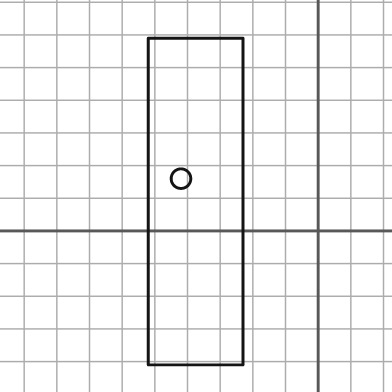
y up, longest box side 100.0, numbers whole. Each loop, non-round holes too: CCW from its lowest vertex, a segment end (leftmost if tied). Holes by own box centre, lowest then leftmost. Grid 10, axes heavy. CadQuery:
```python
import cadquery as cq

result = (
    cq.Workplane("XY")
    .moveTo(-52.0, -41.0)
    .lineTo(-23.0, -41.0)
    .lineTo(-23.0, 59.0)
    .lineTo(-52.0, 59.0)
    .close()
    .moveTo(-42.0, 16.0)
    .circle(3.0)
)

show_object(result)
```